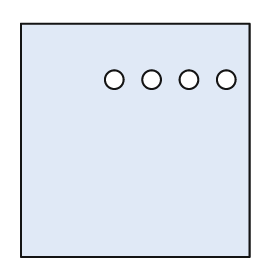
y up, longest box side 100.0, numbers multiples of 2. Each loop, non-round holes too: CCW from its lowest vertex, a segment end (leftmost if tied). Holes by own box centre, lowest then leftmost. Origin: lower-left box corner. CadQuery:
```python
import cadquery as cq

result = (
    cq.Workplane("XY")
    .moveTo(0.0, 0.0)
    .lineTo(98.0, 0.0)
    .lineTo(98.0, 100.0)
    .lineTo(0.0, 100.0)
    .close()
    .moveTo(40.0, 76.0)
    .circle(4.0)
    .moveTo(56.0, 76.0)
    .circle(4.0)
    .moveTo(72.0, 76.0)
    .circle(4.0)
    .moveTo(88.0, 76.0)
    .circle(4.0)
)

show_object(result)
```